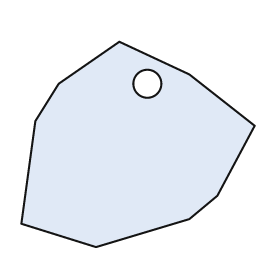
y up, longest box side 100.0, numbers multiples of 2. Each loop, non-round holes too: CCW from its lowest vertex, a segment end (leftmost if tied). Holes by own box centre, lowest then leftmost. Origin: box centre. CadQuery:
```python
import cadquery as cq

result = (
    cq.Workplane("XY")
    .moveTo(-18.0, -44.0)
    .lineTo(22.0, -32.0)
    .lineTo(34.0, -22.0)
    .lineTo(50.0, 8.0)
    .lineTo(22.0, 30.0)
    .lineTo(-8.0, 44.0)
    .lineTo(-34.0, 26.0)
    .lineTo(-44.0, 10.0)
    .lineTo(-50.0, -34.0)
    .close()
    .moveTo(4.0, 26.0)
    .circle(6.0)
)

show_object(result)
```